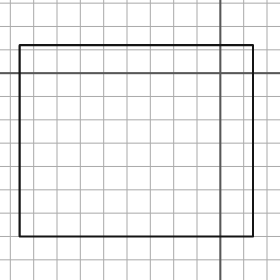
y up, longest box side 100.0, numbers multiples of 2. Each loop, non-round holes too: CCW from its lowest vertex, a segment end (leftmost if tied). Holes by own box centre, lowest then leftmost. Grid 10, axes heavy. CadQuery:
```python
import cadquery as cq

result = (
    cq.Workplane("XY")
    .moveTo(-86.0, -70.0)
    .lineTo(14.0, -70.0)
    .lineTo(14.0, 12.0)
    .lineTo(-86.0, 12.0)
    .close()
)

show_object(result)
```